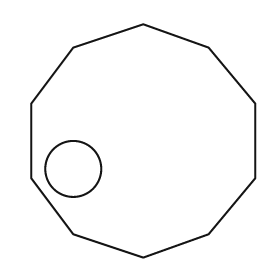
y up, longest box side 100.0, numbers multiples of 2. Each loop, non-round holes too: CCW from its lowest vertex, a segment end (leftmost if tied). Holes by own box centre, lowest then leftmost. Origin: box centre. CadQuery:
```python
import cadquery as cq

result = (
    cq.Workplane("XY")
    .moveTo(0.0, -50.0)
    .lineTo(28.0, -40.0)
    .lineTo(48.0, -16.0)
    .lineTo(48.0, 16.0)
    .lineTo(28.0, 40.0)
    .lineTo(0.0, 50.0)
    .lineTo(-30.0, 40.0)
    .lineTo(-48.0, 16.0)
    .lineTo(-48.0, -16.0)
    .lineTo(-30.0, -40.0)
    .close()
    .moveTo(-30.0, -12.0)
    .circle(12.0)
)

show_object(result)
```